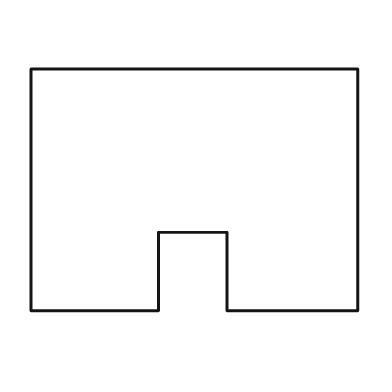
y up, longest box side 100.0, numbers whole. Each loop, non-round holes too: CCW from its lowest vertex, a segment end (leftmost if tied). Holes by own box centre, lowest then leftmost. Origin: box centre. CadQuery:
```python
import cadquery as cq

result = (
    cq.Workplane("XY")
    .moveTo(-50.0, -37.0)
    .lineTo(-11.0, -37.0)
    .lineTo(-11.0, -13.0)
    .lineTo(10.0, -13.0)
    .lineTo(10.0, -37.0)
    .lineTo(50.0, -37.0)
    .lineTo(50.0, 37.0)
    .lineTo(-50.0, 37.0)
    .close()
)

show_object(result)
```